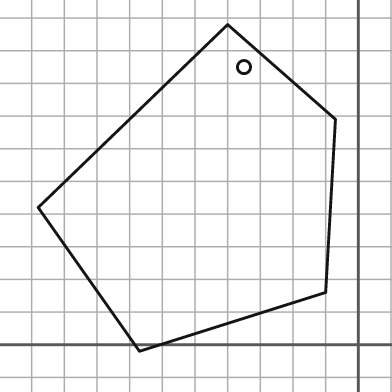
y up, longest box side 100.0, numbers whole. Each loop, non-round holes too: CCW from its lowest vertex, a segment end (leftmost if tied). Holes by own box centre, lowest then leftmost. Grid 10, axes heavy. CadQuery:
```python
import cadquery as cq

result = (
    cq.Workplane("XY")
    .moveTo(-67.0, -2.0)
    .lineTo(-10.0, 16.0)
    .lineTo(-7.0, 69.0)
    .lineTo(-40.0, 98.0)
    .lineTo(-98.0, 42.0)
    .close()
    .moveTo(-35.0, 85.0)
    .circle(2.0)
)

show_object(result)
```